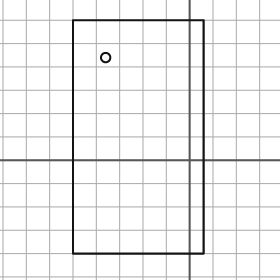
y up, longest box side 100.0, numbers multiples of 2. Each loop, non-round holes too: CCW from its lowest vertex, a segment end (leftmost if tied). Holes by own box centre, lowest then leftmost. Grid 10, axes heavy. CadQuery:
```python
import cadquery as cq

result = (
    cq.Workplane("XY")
    .moveTo(-50.0, -40.0)
    .lineTo(6.0, -40.0)
    .lineTo(6.0, 60.0)
    .lineTo(-50.0, 60.0)
    .close()
    .moveTo(-36.0, 44.0)
    .circle(2.0)
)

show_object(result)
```